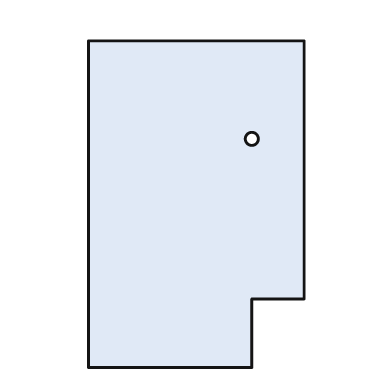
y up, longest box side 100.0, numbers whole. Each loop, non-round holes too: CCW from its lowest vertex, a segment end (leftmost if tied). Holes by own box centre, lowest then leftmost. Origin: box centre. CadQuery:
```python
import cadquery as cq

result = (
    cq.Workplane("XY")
    .moveTo(-33.0, -50.0)
    .lineTo(17.0, -50.0)
    .lineTo(17.0, -29.0)
    .lineTo(33.0, -29.0)
    .lineTo(33.0, 50.0)
    .lineTo(-33.0, 50.0)
    .close()
    .moveTo(17.0, 20.0)
    .circle(2.0)
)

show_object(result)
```